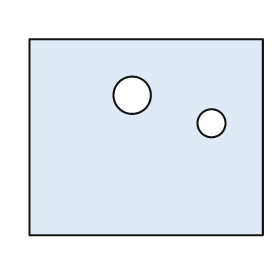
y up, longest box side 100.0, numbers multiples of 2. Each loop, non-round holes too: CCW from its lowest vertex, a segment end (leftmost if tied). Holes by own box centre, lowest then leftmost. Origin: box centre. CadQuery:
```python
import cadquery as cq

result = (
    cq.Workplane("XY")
    .moveTo(-50.0, -42.0)
    .lineTo(50.0, -42.0)
    .lineTo(50.0, 42.0)
    .lineTo(-50.0, 42.0)
    .close()
    .moveTo(28.0, 6.0)
    .circle(6.0)
    .moveTo(-6.0, 18.0)
    .circle(8.0)
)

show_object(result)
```